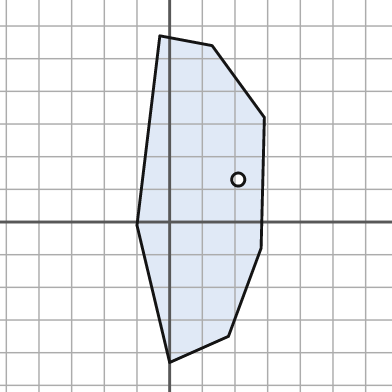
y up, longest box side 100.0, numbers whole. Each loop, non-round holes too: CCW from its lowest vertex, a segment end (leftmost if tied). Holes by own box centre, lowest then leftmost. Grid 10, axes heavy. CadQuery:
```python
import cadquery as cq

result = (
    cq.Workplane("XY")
    .moveTo(0.0, -43.0)
    .lineTo(18.0, -35.0)
    .lineTo(28.0, -8.0)
    .lineTo(29.0, 32.0)
    .lineTo(13.0, 54.0)
    .lineTo(-3.0, 57.0)
    .lineTo(-10.0, -1.0)
    .close()
    .moveTo(21.0, 13.0)
    .circle(2.0)
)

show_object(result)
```